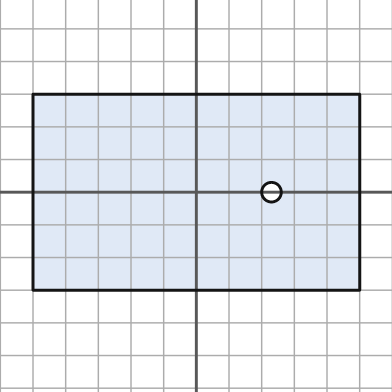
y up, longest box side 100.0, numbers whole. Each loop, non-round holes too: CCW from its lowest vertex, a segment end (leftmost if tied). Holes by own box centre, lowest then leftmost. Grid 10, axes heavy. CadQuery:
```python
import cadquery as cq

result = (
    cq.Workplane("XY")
    .moveTo(-50.0, -30.0)
    .lineTo(50.0, -30.0)
    .lineTo(50.0, 30.0)
    .lineTo(-50.0, 30.0)
    .close()
    .moveTo(23.0, 0.0)
    .circle(3.0)
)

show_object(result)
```